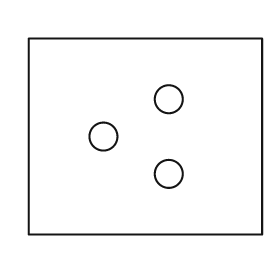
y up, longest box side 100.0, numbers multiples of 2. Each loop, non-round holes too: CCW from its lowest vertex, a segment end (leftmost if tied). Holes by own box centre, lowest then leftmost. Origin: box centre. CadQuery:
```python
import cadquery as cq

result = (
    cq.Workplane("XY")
    .moveTo(-50.0, -42.0)
    .lineTo(50.0, -42.0)
    .lineTo(50.0, 42.0)
    .lineTo(-50.0, 42.0)
    .close()
    .moveTo(10.0, -16.0)
    .circle(6.0)
    .moveTo(-18.0, 0.0)
    .circle(6.0)
    .moveTo(10.0, 16.0)
    .circle(6.0)
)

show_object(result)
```